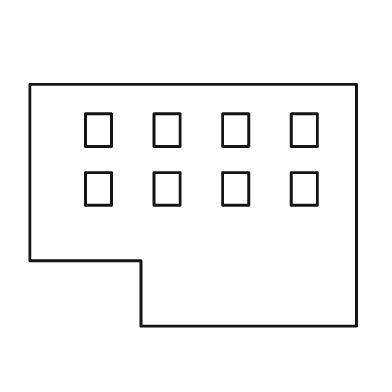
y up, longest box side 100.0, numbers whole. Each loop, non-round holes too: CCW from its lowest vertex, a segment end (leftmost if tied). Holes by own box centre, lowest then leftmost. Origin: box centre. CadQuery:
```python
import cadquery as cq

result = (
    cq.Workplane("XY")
    .moveTo(-16.0, -37.0)
    .lineTo(50.0, -37.0)
    .lineTo(50.0, 37.0)
    .lineTo(-50.0, 37.0)
    .lineTo(-50.0, -17.0)
    .lineTo(-16.0, -17.0)
    .close()
    .moveTo(-33.0, 0.0)
    .lineTo(-25.0, 0.0)
    .lineTo(-25.0, 10.0)
    .lineTo(-33.0, 10.0)
    .close()
    .moveTo(-12.0, 0.0)
    .lineTo(-4.0, 0.0)
    .lineTo(-4.0, 10.0)
    .lineTo(-12.0, 10.0)
    .close()
    .moveTo(9.0, 0.0)
    .lineTo(17.0, 0.0)
    .lineTo(17.0, 10.0)
    .lineTo(9.0, 10.0)
    .close()
    .moveTo(30.0, 0.0)
    .lineTo(38.0, 0.0)
    .lineTo(38.0, 10.0)
    .lineTo(30.0, 10.0)
    .close()
    .moveTo(-33.0, 18.0)
    .lineTo(-25.0, 18.0)
    .lineTo(-25.0, 28.0)
    .lineTo(-33.0, 28.0)
    .close()
    .moveTo(-12.0, 18.0)
    .lineTo(-4.0, 18.0)
    .lineTo(-4.0, 28.0)
    .lineTo(-12.0, 28.0)
    .close()
    .moveTo(9.0, 18.0)
    .lineTo(17.0, 18.0)
    .lineTo(17.0, 28.0)
    .lineTo(9.0, 28.0)
    .close()
    .moveTo(30.0, 18.0)
    .lineTo(38.0, 18.0)
    .lineTo(38.0, 28.0)
    .lineTo(30.0, 28.0)
    .close()
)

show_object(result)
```